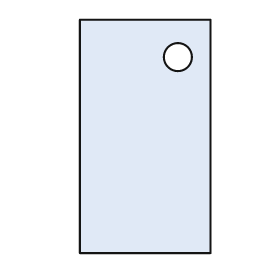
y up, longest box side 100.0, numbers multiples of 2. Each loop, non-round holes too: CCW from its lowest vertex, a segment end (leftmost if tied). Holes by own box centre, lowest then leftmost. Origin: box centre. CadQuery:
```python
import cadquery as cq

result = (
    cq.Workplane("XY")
    .moveTo(-28.0, -50.0)
    .lineTo(28.0, -50.0)
    .lineTo(28.0, 50.0)
    .lineTo(-28.0, 50.0)
    .close()
    .moveTo(14.0, 34.0)
    .circle(6.0)
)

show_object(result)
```